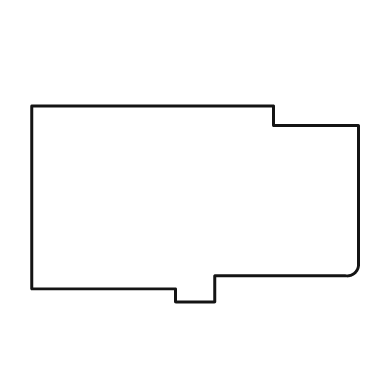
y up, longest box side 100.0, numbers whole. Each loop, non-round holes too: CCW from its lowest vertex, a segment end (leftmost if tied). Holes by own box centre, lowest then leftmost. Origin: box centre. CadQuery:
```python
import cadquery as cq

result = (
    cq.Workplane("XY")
    .moveTo(-6.0, -30.0)
    .lineTo(6.0, -30.0)
    .lineTo(6.0, -22.0)
    .lineTo(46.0, -22.0)
    .threePointArc((49.0, -21.0), (50.0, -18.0))
    .lineTo(50.0, 24.0)
    .lineTo(24.0, 24.0)
    .lineTo(24.0, 30.0)
    .lineTo(-50.0, 30.0)
    .lineTo(-50.0, -26.0)
    .lineTo(-6.0, -26.0)
    .close()
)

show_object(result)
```